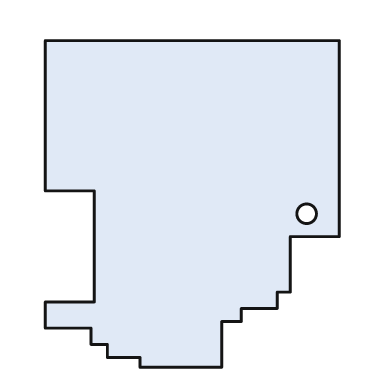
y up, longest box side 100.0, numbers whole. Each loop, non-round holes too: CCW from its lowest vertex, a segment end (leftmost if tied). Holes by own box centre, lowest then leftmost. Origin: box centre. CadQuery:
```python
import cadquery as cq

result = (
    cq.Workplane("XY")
    .moveTo(-16.0, -50.0)
    .lineTo(9.0, -50.0)
    .lineTo(9.0, -36.0)
    .lineTo(15.0, -36.0)
    .lineTo(15.0, -32.0)
    .lineTo(26.0, -32.0)
    .lineTo(26.0, -27.0)
    .lineTo(30.0, -27.0)
    .lineTo(30.0, -10.0)
    .lineTo(45.0, -10.0)
    .lineTo(45.0, 50.0)
    .lineTo(-45.0, 50.0)
    .lineTo(-45.0, 4.0)
    .lineTo(-30.0, 4.0)
    .lineTo(-30.0, -30.0)
    .lineTo(-45.0, -30.0)
    .lineTo(-45.0, -38.0)
    .lineTo(-31.0, -38.0)
    .lineTo(-31.0, -43.0)
    .lineTo(-26.0, -43.0)
    .lineTo(-26.0, -47.0)
    .lineTo(-16.0, -47.0)
    .close()
    .moveTo(35.0, -3.0)
    .circle(3.0)
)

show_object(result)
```